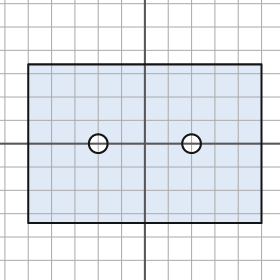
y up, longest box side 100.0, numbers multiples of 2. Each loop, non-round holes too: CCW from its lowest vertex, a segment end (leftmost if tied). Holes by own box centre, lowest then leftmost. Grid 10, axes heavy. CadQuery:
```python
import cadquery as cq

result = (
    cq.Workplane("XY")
    .moveTo(-50.0, -34.0)
    .lineTo(50.0, -34.0)
    .lineTo(50.0, 34.0)
    .lineTo(-50.0, 34.0)
    .close()
    .moveTo(-20.0, 0.0)
    .circle(4.0)
    .moveTo(20.0, 0.0)
    .circle(4.0)
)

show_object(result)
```